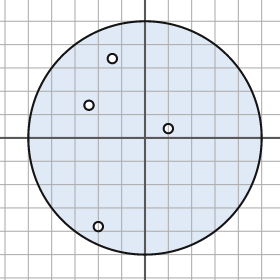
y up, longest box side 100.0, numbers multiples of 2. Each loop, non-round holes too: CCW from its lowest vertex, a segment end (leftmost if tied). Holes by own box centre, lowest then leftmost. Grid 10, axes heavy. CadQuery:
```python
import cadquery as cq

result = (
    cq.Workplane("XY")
    .moveTo(0.0, 0.0)
    .circle(50.0)
    .moveTo(-20.0, -38.0)
    .circle(2.0)
    .moveTo(10.0, 4.0)
    .circle(2.0)
    .moveTo(-24.0, 14.0)
    .circle(2.0)
    .moveTo(-14.0, 34.0)
    .circle(2.0)
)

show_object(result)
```